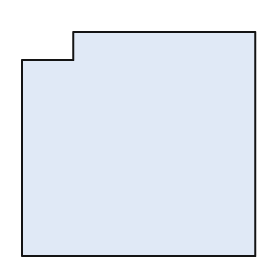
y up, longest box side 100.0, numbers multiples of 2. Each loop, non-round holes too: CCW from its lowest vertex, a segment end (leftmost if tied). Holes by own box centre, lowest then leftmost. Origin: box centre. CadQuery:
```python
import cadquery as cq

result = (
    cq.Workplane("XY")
    .moveTo(-50.0, -48.0)
    .lineTo(50.0, -48.0)
    .lineTo(50.0, 48.0)
    .lineTo(-28.0, 48.0)
    .lineTo(-28.0, 36.0)
    .lineTo(-50.0, 36.0)
    .close()
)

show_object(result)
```